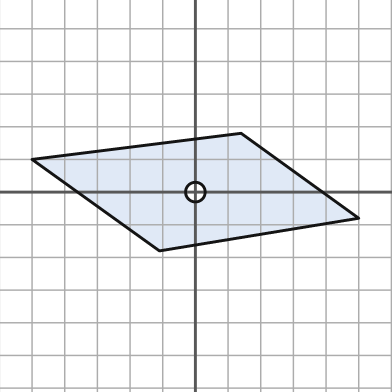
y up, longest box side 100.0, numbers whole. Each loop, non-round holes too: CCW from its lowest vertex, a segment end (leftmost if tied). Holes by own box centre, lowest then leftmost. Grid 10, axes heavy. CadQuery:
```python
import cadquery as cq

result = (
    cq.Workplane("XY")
    .moveTo(-11.0, -18.0)
    .lineTo(50.0, -8.0)
    .lineTo(14.0, 18.0)
    .lineTo(-50.0, 10.0)
    .close()
    .moveTo(0.0, 0.0)
    .circle(3.0)
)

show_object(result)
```